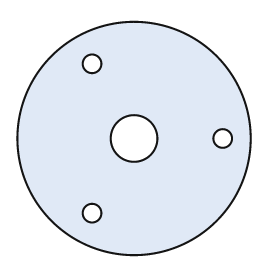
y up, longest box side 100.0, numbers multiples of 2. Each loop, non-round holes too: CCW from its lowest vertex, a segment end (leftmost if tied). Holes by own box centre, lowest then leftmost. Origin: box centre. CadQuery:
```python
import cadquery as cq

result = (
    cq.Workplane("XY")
    .moveTo(0.0, 0.0)
    .circle(50.0)
    .moveTo(-18.0, -32.0)
    .circle(4.0)
    .moveTo(0.0, 0.0)
    .circle(10.0)
    .moveTo(38.0, 0.0)
    .circle(4.0)
    .moveTo(-18.0, 32.0)
    .circle(4.0)
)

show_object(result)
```